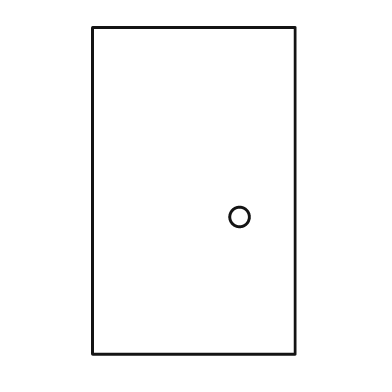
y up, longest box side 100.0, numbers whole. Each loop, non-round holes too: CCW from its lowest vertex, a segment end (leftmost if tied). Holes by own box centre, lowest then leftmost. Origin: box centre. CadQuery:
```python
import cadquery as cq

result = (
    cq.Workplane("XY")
    .moveTo(-31.0, -50.0)
    .lineTo(31.0, -50.0)
    .lineTo(31.0, 50.0)
    .lineTo(-31.0, 50.0)
    .close()
    .moveTo(14.0, -8.0)
    .circle(3.0)
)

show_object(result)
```